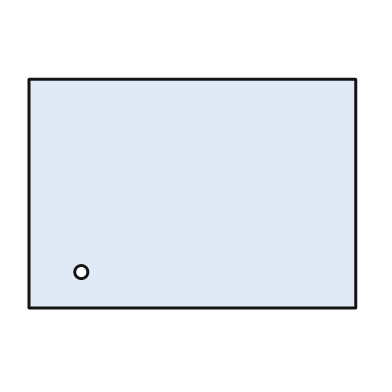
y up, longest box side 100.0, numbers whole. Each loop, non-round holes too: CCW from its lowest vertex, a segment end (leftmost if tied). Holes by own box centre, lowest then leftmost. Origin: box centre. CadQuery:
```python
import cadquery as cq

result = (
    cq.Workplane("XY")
    .moveTo(-50.0, -35.0)
    .lineTo(50.0, -35.0)
    .lineTo(50.0, 35.0)
    .lineTo(-50.0, 35.0)
    .close()
    .moveTo(-34.0, -24.0)
    .circle(2.0)
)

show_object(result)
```